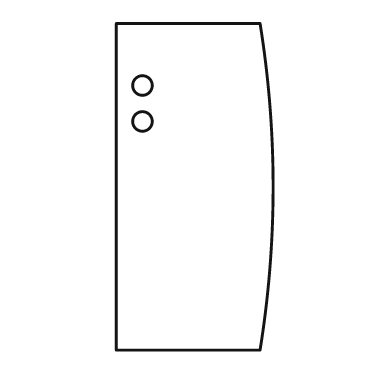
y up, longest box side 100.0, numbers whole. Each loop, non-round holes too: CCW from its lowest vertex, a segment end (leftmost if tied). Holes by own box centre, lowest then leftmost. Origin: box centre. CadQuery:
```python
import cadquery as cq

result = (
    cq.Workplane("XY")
    .moveTo(-24.0, -50.0)
    .lineTo(20.0, -50.0)
    .threePointArc((24.0, 0.0), (20.0, 50.0))
    .lineTo(-24.0, 50.0)
    .close()
    .moveTo(-16.0, 20.0)
    .circle(3.0)
    .moveTo(-16.0, 31.0)
    .circle(3.0)
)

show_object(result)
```